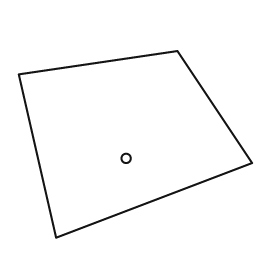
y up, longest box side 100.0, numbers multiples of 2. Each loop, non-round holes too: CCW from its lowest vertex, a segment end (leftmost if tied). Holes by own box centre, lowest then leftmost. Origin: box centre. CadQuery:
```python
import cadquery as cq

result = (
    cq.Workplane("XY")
    .moveTo(-34.0, -40.0)
    .lineTo(50.0, -8.0)
    .lineTo(18.0, 40.0)
    .lineTo(-50.0, 30.0)
    .close()
    .moveTo(-4.0, -6.0)
    .circle(2.0)
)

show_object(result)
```